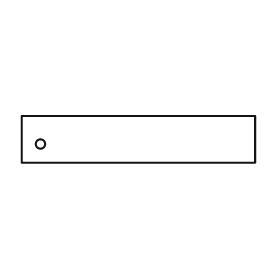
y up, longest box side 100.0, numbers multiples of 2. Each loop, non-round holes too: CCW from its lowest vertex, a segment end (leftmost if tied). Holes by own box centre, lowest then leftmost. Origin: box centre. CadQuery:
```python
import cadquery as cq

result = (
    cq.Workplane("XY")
    .moveTo(-50.0, -10.0)
    .lineTo(50.0, -10.0)
    .lineTo(50.0, 10.0)
    .lineTo(-50.0, 10.0)
    .close()
    .moveTo(-42.0, -2.0)
    .circle(2.0)
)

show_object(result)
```